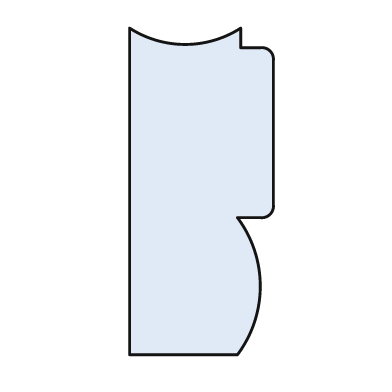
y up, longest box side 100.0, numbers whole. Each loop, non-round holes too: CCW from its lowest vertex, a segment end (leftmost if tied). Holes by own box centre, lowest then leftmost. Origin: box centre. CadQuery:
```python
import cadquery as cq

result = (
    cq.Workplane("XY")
    .moveTo(-22.0, -50.0)
    .lineTo(11.0, -50.0)
    .threePointArc((18.0, -29.0), (11.0, -8.0))
    .lineTo(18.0, -8.0)
    .threePointArc((21.0, -7.0), (22.0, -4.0))
    .lineTo(22.0, 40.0)
    .threePointArc((21.0, 43.0), (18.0, 44.0))
    .lineTo(12.0, 44.0)
    .lineTo(12.0, 50.0)
    .threePointArc((-5.0, 45.0), (-22.0, 50.0))
    .close()
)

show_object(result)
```